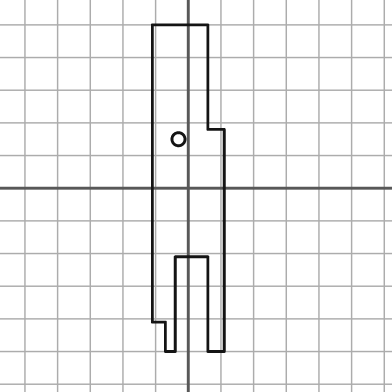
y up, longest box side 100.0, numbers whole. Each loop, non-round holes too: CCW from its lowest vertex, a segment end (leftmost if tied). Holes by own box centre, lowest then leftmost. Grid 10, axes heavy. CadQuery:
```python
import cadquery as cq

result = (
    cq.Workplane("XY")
    .moveTo(-7.0, -50.0)
    .lineTo(-4.0, -50.0)
    .lineTo(-4.0, -21.0)
    .lineTo(6.0, -21.0)
    .lineTo(6.0, -50.0)
    .lineTo(11.0, -50.0)
    .lineTo(11.0, 18.0)
    .lineTo(6.0, 18.0)
    .lineTo(6.0, 50.0)
    .lineTo(-11.0, 50.0)
    .lineTo(-11.0, -41.0)
    .lineTo(-7.0, -41.0)
    .close()
    .moveTo(-3.0, 15.0)
    .circle(2.0)
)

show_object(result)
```